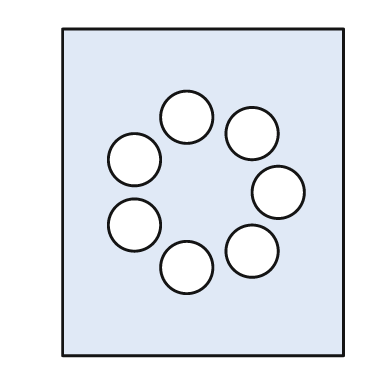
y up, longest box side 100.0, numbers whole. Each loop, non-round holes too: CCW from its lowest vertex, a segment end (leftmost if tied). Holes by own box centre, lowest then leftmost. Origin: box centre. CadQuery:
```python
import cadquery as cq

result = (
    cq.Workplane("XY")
    .moveTo(-43.0, -50.0)
    .lineTo(43.0, -50.0)
    .lineTo(43.0, 50.0)
    .lineTo(-43.0, 50.0)
    .close()
    .moveTo(-5.0, -23.0)
    .circle(8.0)
    .moveTo(15.0, -18.0)
    .circle(8.0)
    .moveTo(-21.0, -10.0)
    .circle(8.0)
    .moveTo(23.0, 0.0)
    .circle(8.0)
    .moveTo(-21.0, 10.0)
    .circle(8.0)
    .moveTo(15.0, 18.0)
    .circle(8.0)
    .moveTo(-5.0, 23.0)
    .circle(8.0)
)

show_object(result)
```